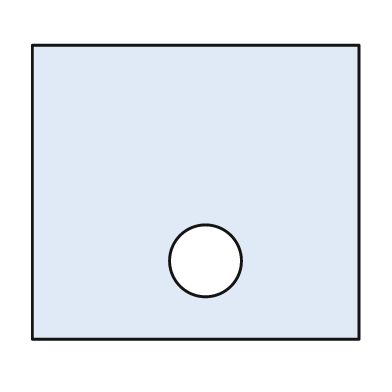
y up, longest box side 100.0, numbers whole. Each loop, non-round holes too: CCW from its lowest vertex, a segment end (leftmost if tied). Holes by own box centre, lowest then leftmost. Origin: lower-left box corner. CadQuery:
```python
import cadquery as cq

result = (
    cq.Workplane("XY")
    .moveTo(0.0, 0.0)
    .lineTo(100.0, 0.0)
    .lineTo(100.0, 90.0)
    .lineTo(0.0, 90.0)
    .close()
    .moveTo(53.0, 24.0)
    .circle(11.0)
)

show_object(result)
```